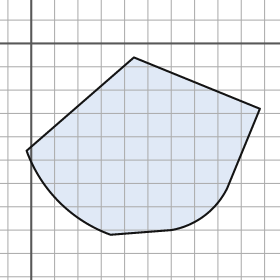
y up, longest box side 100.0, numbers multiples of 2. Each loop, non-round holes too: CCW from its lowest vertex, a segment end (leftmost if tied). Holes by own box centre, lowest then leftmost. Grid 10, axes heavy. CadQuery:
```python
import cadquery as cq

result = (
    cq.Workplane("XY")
    .moveTo(34.0, -82.0)
    .lineTo(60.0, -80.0)
    .threePointArc((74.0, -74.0), (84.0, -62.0))
    .lineTo(98.0, -28.0)
    .lineTo(44.0, -6.0)
    .lineTo(-2.0, -46.0)
    .threePointArc((12.0, -68.0), (34.0, -82.0))
    .close()
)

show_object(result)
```